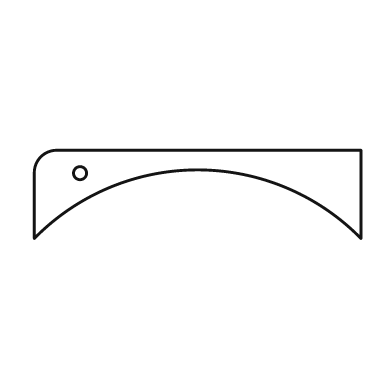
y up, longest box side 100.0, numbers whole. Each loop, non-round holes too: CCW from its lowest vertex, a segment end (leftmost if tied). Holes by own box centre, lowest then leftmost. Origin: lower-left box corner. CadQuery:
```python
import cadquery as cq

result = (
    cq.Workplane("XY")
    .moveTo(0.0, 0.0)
    .threePointArc((50.0, 21.0), (100.0, 0.0))
    .lineTo(100.0, 27.0)
    .lineTo(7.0, 27.0)
    .threePointArc((2.0, 25.0), (0.0, 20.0))
    .close()
    .moveTo(14.0, 20.0)
    .circle(2.0)
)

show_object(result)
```